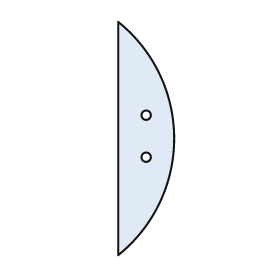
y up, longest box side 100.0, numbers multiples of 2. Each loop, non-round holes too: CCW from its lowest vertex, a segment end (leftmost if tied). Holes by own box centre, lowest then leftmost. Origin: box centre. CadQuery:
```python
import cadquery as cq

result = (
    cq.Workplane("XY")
    .moveTo(-12.0, -50.0)
    .threePointArc((12.0, 0.0), (-12.0, 50.0))
    .close()
    .moveTo(0.0, -8.0)
    .circle(2.0)
    .moveTo(0.0, 10.0)
    .circle(2.0)
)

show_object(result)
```